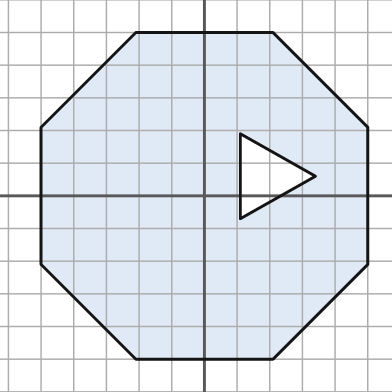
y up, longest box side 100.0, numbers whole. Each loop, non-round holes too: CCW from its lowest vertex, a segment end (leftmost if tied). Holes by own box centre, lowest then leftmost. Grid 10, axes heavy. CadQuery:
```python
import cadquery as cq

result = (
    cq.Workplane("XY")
    .moveTo(-21.0, -50.0)
    .lineTo(21.0, -50.0)
    .lineTo(50.0, -21.0)
    .lineTo(50.0, 21.0)
    .lineTo(21.0, 50.0)
    .lineTo(-21.0, 50.0)
    .lineTo(-50.0, 21.0)
    .lineTo(-50.0, -21.0)
    .close()
    .moveTo(11.0, -7.0)
    .lineTo(34.0, 6.0)
    .lineTo(11.0, 19.0)
    .close()
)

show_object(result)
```